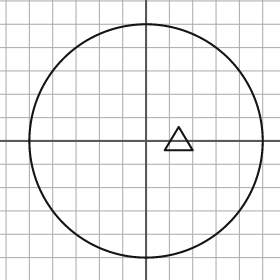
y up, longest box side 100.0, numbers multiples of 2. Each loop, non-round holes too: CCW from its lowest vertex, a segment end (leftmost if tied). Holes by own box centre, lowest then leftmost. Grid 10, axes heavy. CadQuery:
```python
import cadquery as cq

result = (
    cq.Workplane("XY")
    .moveTo(0.0, 0.0)
    .circle(50.0)
    .moveTo(8.0, -4.0)
    .lineTo(20.0, -4.0)
    .lineTo(14.0, 6.0)
    .close()
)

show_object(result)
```